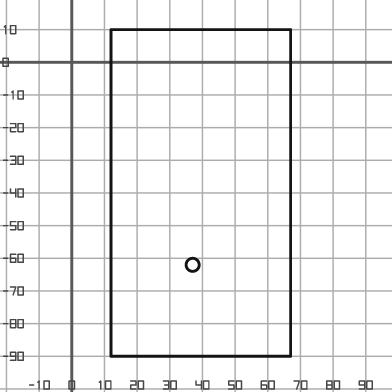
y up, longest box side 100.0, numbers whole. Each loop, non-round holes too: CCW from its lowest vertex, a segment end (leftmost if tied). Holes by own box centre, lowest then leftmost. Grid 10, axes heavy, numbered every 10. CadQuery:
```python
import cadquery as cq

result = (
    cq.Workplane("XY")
    .moveTo(12.0, -90.0)
    .lineTo(67.0, -90.0)
    .lineTo(67.0, 10.0)
    .lineTo(12.0, 10.0)
    .close()
    .moveTo(37.0, -62.0)
    .circle(2.0)
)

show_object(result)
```